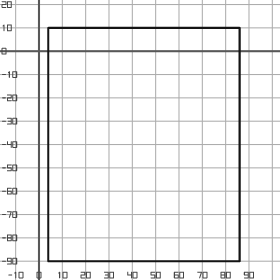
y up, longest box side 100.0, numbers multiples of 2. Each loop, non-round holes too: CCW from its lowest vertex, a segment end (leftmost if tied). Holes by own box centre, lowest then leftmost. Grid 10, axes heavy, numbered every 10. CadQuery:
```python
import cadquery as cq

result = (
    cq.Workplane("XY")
    .moveTo(4.0, -90.0)
    .lineTo(86.0, -90.0)
    .lineTo(86.0, 10.0)
    .lineTo(4.0, 10.0)
    .close()
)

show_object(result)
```